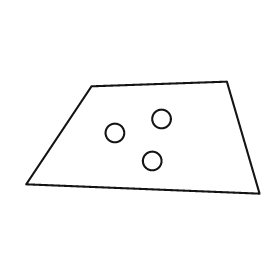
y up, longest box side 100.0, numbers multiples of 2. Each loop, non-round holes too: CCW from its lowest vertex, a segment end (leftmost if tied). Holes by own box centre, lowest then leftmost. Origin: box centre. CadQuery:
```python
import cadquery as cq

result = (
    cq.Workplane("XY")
    .moveTo(50.0, -24.0)
    .lineTo(36.0, 24.0)
    .lineTo(-22.0, 22.0)
    .lineTo(-50.0, -20.0)
    .close()
    .moveTo(4.0, -10.0)
    .circle(4.0)
    .moveTo(-12.0, 2.0)
    .circle(4.0)
    .moveTo(8.0, 8.0)
    .circle(4.0)
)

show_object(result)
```